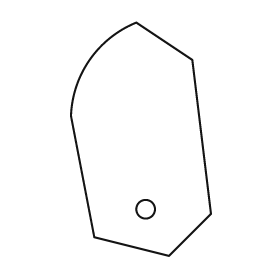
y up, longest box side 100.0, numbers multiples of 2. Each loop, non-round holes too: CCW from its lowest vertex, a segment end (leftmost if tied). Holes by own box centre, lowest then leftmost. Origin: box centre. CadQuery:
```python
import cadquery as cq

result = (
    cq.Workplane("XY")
    .moveTo(12.0, -50.0)
    .lineTo(30.0, -32.0)
    .lineTo(22.0, 34.0)
    .lineTo(-2.0, 50.0)
    .threePointArc((-22.0, 34.0), (-30.0, 10.0))
    .lineTo(-20.0, -42.0)
    .close()
    .moveTo(2.0, -30.0)
    .circle(4.0)
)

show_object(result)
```